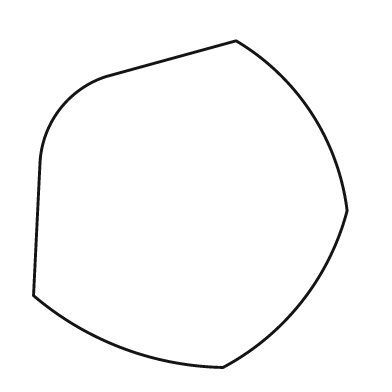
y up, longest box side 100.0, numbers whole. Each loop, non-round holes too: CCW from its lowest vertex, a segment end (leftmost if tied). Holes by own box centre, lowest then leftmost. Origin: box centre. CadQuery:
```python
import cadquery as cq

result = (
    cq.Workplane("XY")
    .moveTo(10.0, -50.0)
    .threePointArc((34.0, -30.0), (48.0, -2.0))
    .threePointArc((37.0, 28.0), (14.0, 50.0))
    .lineTo(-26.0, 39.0)
    .threePointArc((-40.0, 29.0), (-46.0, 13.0))
    .lineTo(-48.0, -28.0)
    .threePointArc((-21.0, -44.0), (10.0, -50.0))
    .close()
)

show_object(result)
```